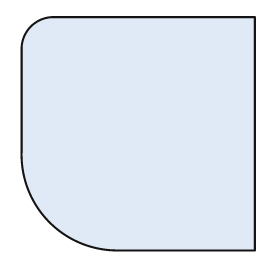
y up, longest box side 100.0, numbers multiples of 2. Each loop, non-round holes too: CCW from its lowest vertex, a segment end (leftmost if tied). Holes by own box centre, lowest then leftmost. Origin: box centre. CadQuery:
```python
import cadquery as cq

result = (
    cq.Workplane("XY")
    .moveTo(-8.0, -50.0)
    .lineTo(50.0, -50.0)
    .lineTo(50.0, 50.0)
    .lineTo(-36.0, 50.0)
    .threePointArc((-46.0, 46.0), (-50.0, 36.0))
    .lineTo(-50.0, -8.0)
    .threePointArc((-38.0, -38.0), (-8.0, -50.0))
    .close()
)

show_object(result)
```